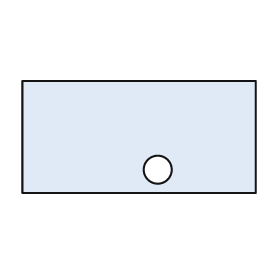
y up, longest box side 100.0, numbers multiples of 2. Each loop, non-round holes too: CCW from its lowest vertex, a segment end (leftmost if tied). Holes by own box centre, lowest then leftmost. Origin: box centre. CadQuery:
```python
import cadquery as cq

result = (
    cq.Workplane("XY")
    .moveTo(-50.0, -24.0)
    .lineTo(50.0, -24.0)
    .lineTo(50.0, 24.0)
    .lineTo(-50.0, 24.0)
    .close()
    .moveTo(8.0, -14.0)
    .circle(6.0)
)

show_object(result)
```